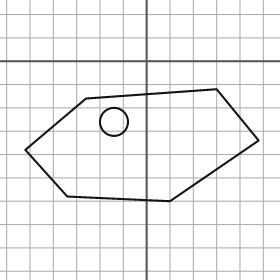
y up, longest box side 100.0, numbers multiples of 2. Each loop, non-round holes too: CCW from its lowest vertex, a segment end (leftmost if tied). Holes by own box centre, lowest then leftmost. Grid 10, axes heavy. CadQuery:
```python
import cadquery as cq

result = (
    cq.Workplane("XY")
    .moveTo(10.0, -60.0)
    .lineTo(48.0, -34.0)
    .lineTo(30.0, -12.0)
    .lineTo(-26.0, -16.0)
    .lineTo(-52.0, -38.0)
    .lineTo(-34.0, -58.0)
    .close()
    .moveTo(-14.0, -26.0)
    .circle(6.0)
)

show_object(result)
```